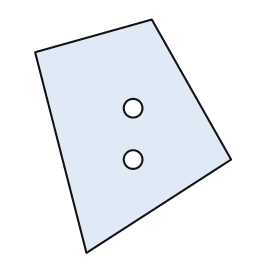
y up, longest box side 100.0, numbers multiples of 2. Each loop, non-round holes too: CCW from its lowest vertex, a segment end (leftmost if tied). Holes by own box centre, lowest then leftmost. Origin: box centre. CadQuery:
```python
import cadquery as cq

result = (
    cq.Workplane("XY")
    .moveTo(-20.0, -50.0)
    .lineTo(42.0, -10.0)
    .lineTo(8.0, 50.0)
    .lineTo(-42.0, 36.0)
    .close()
    .moveTo(0.0, -10.0)
    .circle(4.0)
    .moveTo(0.0, 12.0)
    .circle(4.0)
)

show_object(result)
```